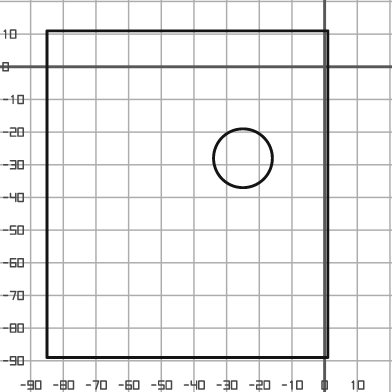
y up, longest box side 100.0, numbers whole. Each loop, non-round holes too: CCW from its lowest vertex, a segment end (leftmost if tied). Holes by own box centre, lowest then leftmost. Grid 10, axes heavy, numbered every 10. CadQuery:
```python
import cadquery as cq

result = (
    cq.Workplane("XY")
    .moveTo(-85.0, -89.0)
    .lineTo(1.0, -89.0)
    .lineTo(1.0, 11.0)
    .lineTo(-85.0, 11.0)
    .close()
    .moveTo(-25.0, -28.0)
    .circle(9.0)
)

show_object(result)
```